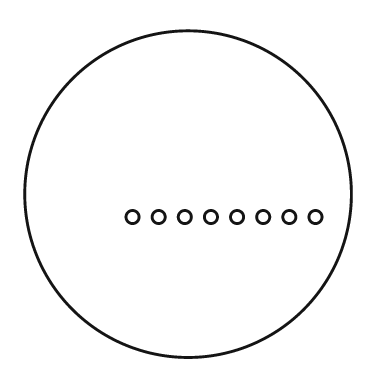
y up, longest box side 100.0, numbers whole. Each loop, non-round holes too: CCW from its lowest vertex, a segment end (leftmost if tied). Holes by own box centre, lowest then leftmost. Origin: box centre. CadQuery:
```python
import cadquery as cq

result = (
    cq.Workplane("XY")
    .moveTo(0.0, 0.0)
    .circle(50.0)
    .moveTo(-17.0, -7.0)
    .circle(2.0)
    .moveTo(-9.0, -7.0)
    .circle(2.0)
    .moveTo(-1.0, -7.0)
    .circle(2.0)
    .moveTo(7.0, -7.0)
    .circle(2.0)
    .moveTo(15.0, -7.0)
    .circle(2.0)
    .moveTo(23.0, -7.0)
    .circle(2.0)
    .moveTo(31.0, -7.0)
    .circle(2.0)
    .moveTo(39.0, -7.0)
    .circle(2.0)
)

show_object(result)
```